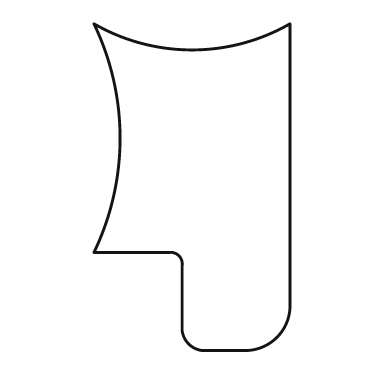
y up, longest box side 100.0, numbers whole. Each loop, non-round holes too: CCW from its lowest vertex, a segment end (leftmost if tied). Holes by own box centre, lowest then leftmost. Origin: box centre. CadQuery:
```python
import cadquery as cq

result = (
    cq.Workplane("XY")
    .moveTo(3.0, -50.0)
    .lineTo(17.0, -50.0)
    .threePointArc((26.0, -46.0), (30.0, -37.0))
    .lineTo(30.0, 50.0)
    .threePointArc((0.0, 42.0), (-30.0, 50.0))
    .threePointArc((-22.0, 15.0), (-30.0, -20.0))
    .lineTo(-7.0, -20.0)
    .threePointArc((-4.0, -21.0), (-3.0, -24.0))
    .lineTo(-3.0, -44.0)
    .threePointArc((-1.0, -48.0), (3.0, -50.0))
    .close()
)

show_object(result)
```